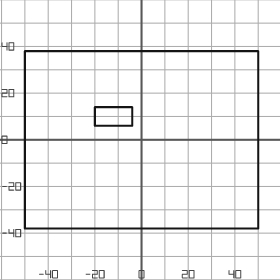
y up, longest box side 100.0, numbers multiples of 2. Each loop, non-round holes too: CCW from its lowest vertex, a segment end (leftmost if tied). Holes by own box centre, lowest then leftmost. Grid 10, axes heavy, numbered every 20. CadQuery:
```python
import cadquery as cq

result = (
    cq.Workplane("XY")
    .moveTo(-50.0, -38.0)
    .lineTo(50.0, -38.0)
    .lineTo(50.0, 38.0)
    .lineTo(-50.0, 38.0)
    .close()
    .moveTo(-20.0, 6.0)
    .lineTo(-4.0, 6.0)
    .lineTo(-4.0, 14.0)
    .lineTo(-20.0, 14.0)
    .close()
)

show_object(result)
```